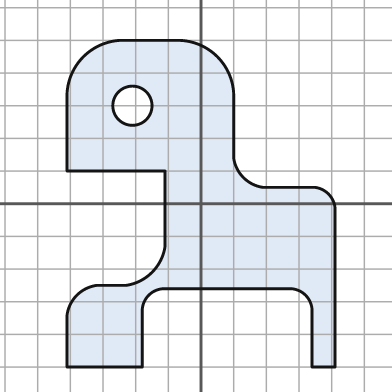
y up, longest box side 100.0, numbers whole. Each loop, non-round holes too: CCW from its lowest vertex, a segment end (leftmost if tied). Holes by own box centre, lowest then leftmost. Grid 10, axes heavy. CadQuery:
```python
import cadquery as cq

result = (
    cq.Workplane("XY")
    .moveTo(-41.0, -50.0)
    .lineTo(-18.0, -50.0)
    .lineTo(-18.0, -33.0)
    .threePointArc((-16.0, -28.0), (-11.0, -26.0))
    .lineTo(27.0, -26.0)
    .threePointArc((32.0, -28.0), (34.0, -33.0))
    .lineTo(34.0, -50.0)
    .lineTo(41.0, -50.0)
    .lineTo(41.0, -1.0)
    .threePointArc((39.0, 3.0), (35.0, 5.0))
    .lineTo(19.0, 5.0)
    .threePointArc((13.0, 8.0), (10.0, 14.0))
    .lineTo(10.0, 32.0)
    .threePointArc((5.0, 45.0), (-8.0, 50.0))
    .lineTo(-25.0, 50.0)
    .threePointArc((-36.0, 45.0), (-41.0, 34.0))
    .lineTo(-41.0, 10.0)
    .lineTo(-11.0, 10.0)
    .lineTo(-11.0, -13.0)
    .threePointArc((-15.0, -21.0), (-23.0, -25.0))
    .lineTo(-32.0, -25.0)
    .threePointArc((-38.0, -28.0), (-41.0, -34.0))
    .close()
    .moveTo(-21.0, 30.0)
    .circle(6.0)
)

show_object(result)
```